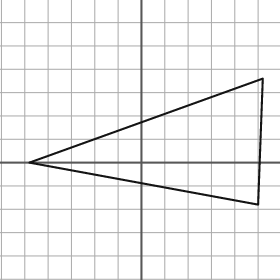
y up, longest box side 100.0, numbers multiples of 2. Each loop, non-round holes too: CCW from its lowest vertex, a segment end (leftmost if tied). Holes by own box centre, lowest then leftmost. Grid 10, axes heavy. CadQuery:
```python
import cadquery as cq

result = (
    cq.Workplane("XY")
    .moveTo(50.0, -18.0)
    .lineTo(52.0, 36.0)
    .lineTo(-48.0, 0.0)
    .close()
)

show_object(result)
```